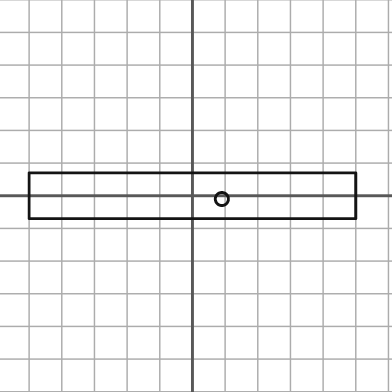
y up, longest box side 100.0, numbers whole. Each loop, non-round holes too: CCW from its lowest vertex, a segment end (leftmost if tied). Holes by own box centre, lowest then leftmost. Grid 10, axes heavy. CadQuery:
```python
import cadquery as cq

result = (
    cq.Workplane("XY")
    .moveTo(-50.0, -7.0)
    .lineTo(50.0, -7.0)
    .lineTo(50.0, 7.0)
    .lineTo(-50.0, 7.0)
    .close()
    .moveTo(9.0, -1.0)
    .circle(2.0)
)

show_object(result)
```